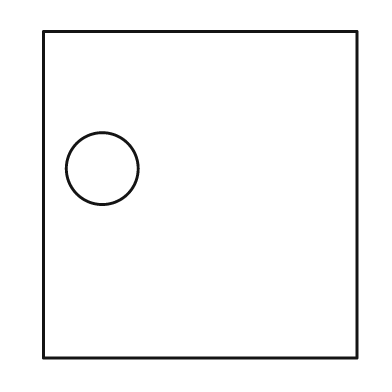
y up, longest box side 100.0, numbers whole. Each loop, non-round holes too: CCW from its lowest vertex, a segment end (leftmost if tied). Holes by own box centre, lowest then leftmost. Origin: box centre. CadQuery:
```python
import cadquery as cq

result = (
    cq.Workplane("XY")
    .moveTo(-48.0, -50.0)
    .lineTo(48.0, -50.0)
    .lineTo(48.0, 50.0)
    .lineTo(-48.0, 50.0)
    .close()
    .moveTo(-30.0, 8.0)
    .circle(11.0)
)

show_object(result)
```